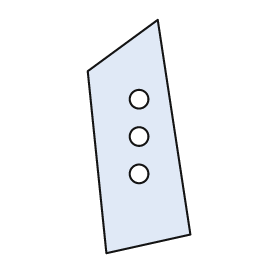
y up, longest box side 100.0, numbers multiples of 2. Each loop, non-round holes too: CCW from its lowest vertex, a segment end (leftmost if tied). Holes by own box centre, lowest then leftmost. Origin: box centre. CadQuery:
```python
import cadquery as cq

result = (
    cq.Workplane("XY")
    .moveTo(-14.0, -50.0)
    .lineTo(22.0, -42.0)
    .lineTo(8.0, 50.0)
    .lineTo(-22.0, 28.0)
    .close()
    .moveTo(0.0, -16.0)
    .circle(4.0)
    .moveTo(0.0, 0.0)
    .circle(4.0)
    .moveTo(0.0, 16.0)
    .circle(4.0)
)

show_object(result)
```